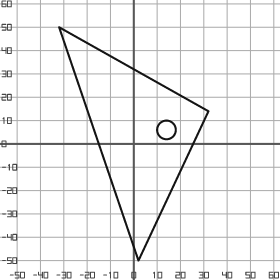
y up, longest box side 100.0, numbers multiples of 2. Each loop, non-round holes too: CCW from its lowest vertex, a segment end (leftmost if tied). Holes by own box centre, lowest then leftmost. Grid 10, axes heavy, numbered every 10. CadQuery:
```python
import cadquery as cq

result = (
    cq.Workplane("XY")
    .moveTo(2.0, -50.0)
    .lineTo(32.0, 14.0)
    .lineTo(-32.0, 50.0)
    .close()
    .moveTo(14.0, 6.0)
    .circle(4.0)
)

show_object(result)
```